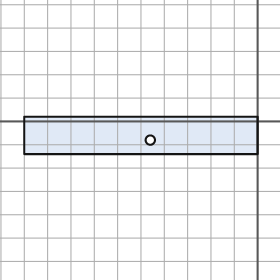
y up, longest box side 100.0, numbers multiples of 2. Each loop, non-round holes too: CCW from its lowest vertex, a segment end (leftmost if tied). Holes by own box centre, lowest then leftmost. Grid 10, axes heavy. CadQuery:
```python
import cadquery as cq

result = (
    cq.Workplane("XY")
    .moveTo(-100.0, -14.0)
    .lineTo(0.0, -14.0)
    .lineTo(0.0, 2.0)
    .lineTo(-100.0, 2.0)
    .close()
    .moveTo(-46.0, -8.0)
    .circle(2.0)
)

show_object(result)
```